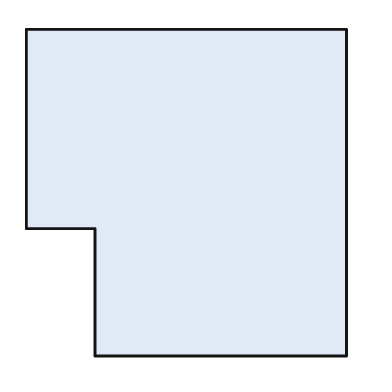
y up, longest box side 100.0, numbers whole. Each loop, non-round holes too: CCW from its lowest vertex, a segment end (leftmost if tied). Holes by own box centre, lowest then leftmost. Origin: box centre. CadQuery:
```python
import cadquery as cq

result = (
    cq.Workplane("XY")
    .moveTo(-28.0, -50.0)
    .lineTo(49.0, -50.0)
    .lineTo(49.0, 50.0)
    .lineTo(-49.0, 50.0)
    .lineTo(-49.0, -11.0)
    .lineTo(-28.0, -11.0)
    .close()
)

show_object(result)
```